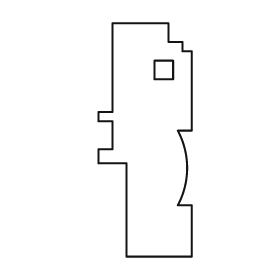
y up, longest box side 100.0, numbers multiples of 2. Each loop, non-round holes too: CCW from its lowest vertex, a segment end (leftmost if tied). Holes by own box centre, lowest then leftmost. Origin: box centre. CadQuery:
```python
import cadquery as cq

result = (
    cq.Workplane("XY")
    .moveTo(-8.0, -50.0)
    .lineTo(20.0, -50.0)
    .lineTo(20.0, -28.0)
    .lineTo(14.0, -28.0)
    .threePointArc((18.0, -12.0), (14.0, 4.0))
    .lineTo(20.0, 4.0)
    .lineTo(20.0, 38.0)
    .lineTo(16.0, 38.0)
    .lineTo(16.0, 42.0)
    .lineTo(10.0, 42.0)
    .lineTo(10.0, 50.0)
    .lineTo(-14.0, 50.0)
    .lineTo(-14.0, 12.0)
    .lineTo(-20.0, 12.0)
    .lineTo(-20.0, 8.0)
    .lineTo(-14.0, 8.0)
    .lineTo(-14.0, -4.0)
    .lineTo(-20.0, -4.0)
    .lineTo(-20.0, -10.0)
    .lineTo(-8.0, -10.0)
    .close()
    .moveTo(4.0, 26.0)
    .lineTo(12.0, 26.0)
    .lineTo(12.0, 34.0)
    .lineTo(4.0, 34.0)
    .close()
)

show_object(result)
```